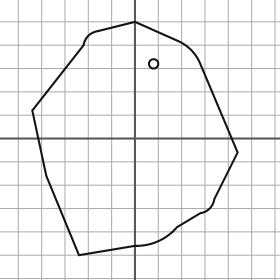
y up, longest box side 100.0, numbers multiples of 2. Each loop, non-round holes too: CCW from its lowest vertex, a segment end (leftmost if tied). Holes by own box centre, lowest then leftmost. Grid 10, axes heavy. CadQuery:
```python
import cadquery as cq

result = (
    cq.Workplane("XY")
    .moveTo(-24.0, -50.0)
    .lineTo(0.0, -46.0)
    .threePointArc((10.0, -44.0), (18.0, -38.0))
    .lineTo(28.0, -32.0)
    .threePointArc((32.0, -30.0), (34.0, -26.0))
    .lineTo(44.0, -6.0)
    .lineTo(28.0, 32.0)
    .threePointArc((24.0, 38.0), (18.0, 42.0))
    .lineTo(0.0, 50.0)
    .lineTo(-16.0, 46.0)
    .threePointArc((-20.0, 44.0), (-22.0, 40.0))
    .lineTo(-44.0, 12.0)
    .lineTo(-38.0, -16.0)
    .close()
    .moveTo(8.0, 32.0)
    .circle(2.0)
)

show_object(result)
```